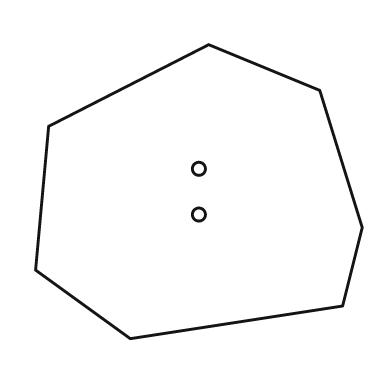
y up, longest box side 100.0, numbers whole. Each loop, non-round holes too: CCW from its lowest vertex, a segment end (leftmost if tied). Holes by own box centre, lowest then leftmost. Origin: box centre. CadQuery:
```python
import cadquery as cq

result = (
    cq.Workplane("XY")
    .moveTo(-21.0, -45.0)
    .lineTo(44.0, -35.0)
    .lineTo(50.0, -11.0)
    .lineTo(37.0, 31.0)
    .lineTo(3.0, 45.0)
    .lineTo(-46.0, 20.0)
    .lineTo(-50.0, -24.0)
    .close()
    .moveTo(0.0, -7.0)
    .circle(2.0)
    .moveTo(0.0, 7.0)
    .circle(2.0)
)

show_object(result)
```